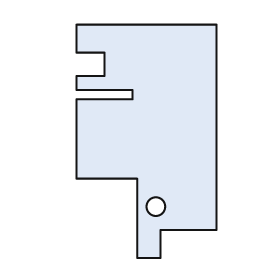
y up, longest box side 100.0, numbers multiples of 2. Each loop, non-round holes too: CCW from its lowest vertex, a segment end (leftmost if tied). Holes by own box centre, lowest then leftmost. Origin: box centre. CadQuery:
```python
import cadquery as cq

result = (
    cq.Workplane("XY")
    .moveTo(-4.0, -50.0)
    .lineTo(6.0, -50.0)
    .lineTo(6.0, -38.0)
    .lineTo(30.0, -38.0)
    .lineTo(30.0, 50.0)
    .lineTo(-30.0, 50.0)
    .lineTo(-30.0, 38.0)
    .lineTo(-18.0, 38.0)
    .lineTo(-18.0, 28.0)
    .lineTo(-30.0, 28.0)
    .lineTo(-30.0, 22.0)
    .lineTo(-6.0, 22.0)
    .lineTo(-6.0, 18.0)
    .lineTo(-30.0, 18.0)
    .lineTo(-30.0, -16.0)
    .lineTo(-4.0, -16.0)
    .close()
    .moveTo(4.0, -28.0)
    .circle(4.0)
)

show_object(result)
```